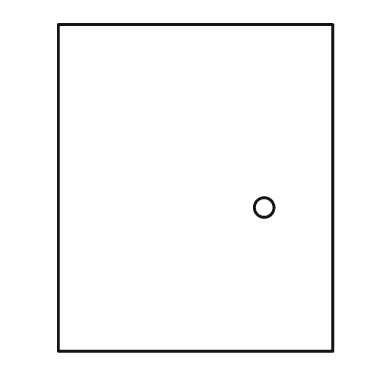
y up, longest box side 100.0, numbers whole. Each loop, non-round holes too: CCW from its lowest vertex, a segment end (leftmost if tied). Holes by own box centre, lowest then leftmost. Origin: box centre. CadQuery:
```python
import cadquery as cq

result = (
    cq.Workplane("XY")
    .moveTo(-42.0, -50.0)
    .lineTo(42.0, -50.0)
    .lineTo(42.0, 50.0)
    .lineTo(-42.0, 50.0)
    .close()
    .moveTo(21.0, -6.0)
    .circle(3.0)
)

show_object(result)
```